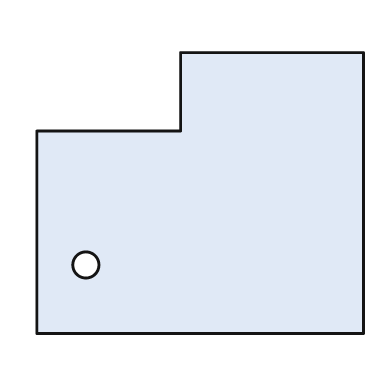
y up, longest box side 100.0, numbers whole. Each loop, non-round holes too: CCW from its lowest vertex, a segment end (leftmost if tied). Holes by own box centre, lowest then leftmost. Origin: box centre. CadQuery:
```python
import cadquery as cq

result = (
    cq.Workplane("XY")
    .moveTo(-50.0, -43.0)
    .lineTo(50.0, -43.0)
    .lineTo(50.0, 43.0)
    .lineTo(-6.0, 43.0)
    .lineTo(-6.0, 19.0)
    .lineTo(-50.0, 19.0)
    .close()
    .moveTo(-35.0, -22.0)
    .circle(4.0)
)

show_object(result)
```